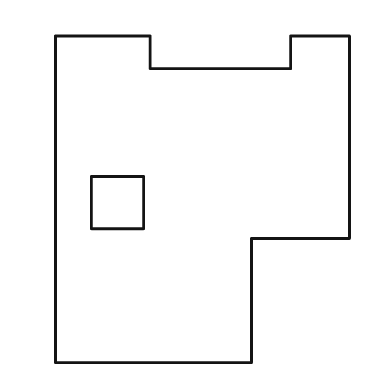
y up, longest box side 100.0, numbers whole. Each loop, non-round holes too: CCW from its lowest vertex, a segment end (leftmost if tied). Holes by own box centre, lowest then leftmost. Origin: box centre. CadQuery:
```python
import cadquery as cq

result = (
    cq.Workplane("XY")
    .moveTo(-45.0, -50.0)
    .lineTo(15.0, -50.0)
    .lineTo(15.0, -12.0)
    .lineTo(45.0, -12.0)
    .lineTo(45.0, 50.0)
    .lineTo(27.0, 50.0)
    .lineTo(27.0, 40.0)
    .lineTo(-16.0, 40.0)
    .lineTo(-16.0, 50.0)
    .lineTo(-45.0, 50.0)
    .close()
    .moveTo(-34.0, -9.0)
    .lineTo(-18.0, -9.0)
    .lineTo(-18.0, 7.0)
    .lineTo(-34.0, 7.0)
    .close()
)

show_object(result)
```